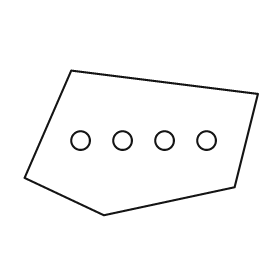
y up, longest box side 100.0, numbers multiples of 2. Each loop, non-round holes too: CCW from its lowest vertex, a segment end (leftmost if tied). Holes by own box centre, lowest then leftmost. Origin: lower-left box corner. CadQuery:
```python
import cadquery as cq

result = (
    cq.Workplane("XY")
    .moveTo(34.0, 0.0)
    .lineTo(90.0, 12.0)
    .lineTo(100.0, 52.0)
    .lineTo(20.0, 62.0)
    .lineTo(0.0, 16.0)
    .close()
    .moveTo(24.0, 32.0)
    .circle(4.0)
    .moveTo(42.0, 32.0)
    .circle(4.0)
    .moveTo(60.0, 32.0)
    .circle(4.0)
    .moveTo(78.0, 32.0)
    .circle(4.0)
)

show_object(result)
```